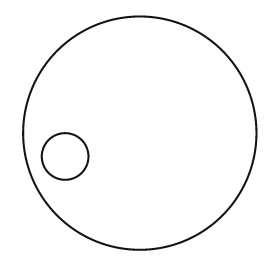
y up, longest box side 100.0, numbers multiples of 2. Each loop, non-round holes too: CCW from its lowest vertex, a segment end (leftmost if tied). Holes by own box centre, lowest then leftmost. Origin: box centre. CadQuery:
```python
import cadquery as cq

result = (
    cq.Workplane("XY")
    .moveTo(0.0, 0.0)
    .circle(50.0)
    .moveTo(-32.0, -10.0)
    .circle(10.0)
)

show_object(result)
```